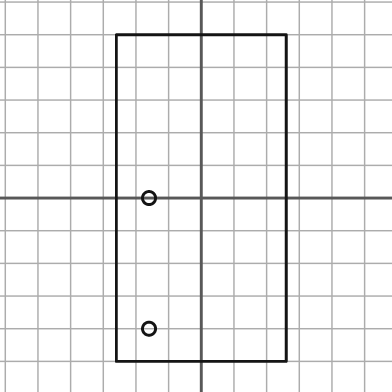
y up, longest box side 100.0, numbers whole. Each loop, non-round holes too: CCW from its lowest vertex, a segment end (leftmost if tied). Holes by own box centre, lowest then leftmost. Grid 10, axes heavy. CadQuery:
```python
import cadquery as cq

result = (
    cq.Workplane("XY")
    .moveTo(-26.0, -50.0)
    .lineTo(26.0, -50.0)
    .lineTo(26.0, 50.0)
    .lineTo(-26.0, 50.0)
    .close()
    .moveTo(-16.0, -40.0)
    .circle(2.0)
    .moveTo(-16.0, 0.0)
    .circle(2.0)
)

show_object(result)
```